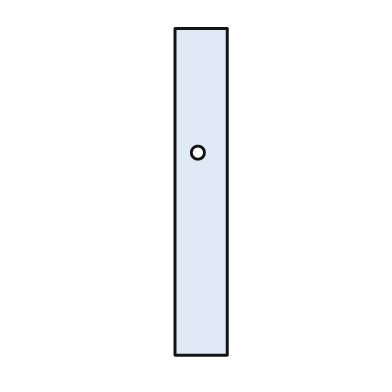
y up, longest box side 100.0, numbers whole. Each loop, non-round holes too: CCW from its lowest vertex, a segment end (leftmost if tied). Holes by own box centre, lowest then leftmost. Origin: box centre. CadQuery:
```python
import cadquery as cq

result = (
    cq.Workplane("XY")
    .moveTo(-8.0, -50.0)
    .lineTo(8.0, -50.0)
    .lineTo(8.0, 50.0)
    .lineTo(-8.0, 50.0)
    .close()
    .moveTo(-1.0, 12.0)
    .circle(2.0)
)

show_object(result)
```